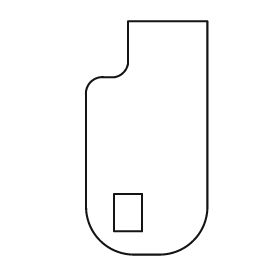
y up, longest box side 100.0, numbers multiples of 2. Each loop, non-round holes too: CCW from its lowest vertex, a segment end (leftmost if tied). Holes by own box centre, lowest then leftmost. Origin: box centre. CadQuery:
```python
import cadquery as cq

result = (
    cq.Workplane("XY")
    .moveTo(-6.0, -50.0)
    .lineTo(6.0, -50.0)
    .threePointArc((20.0, -44.0), (26.0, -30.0))
    .lineTo(26.0, 50.0)
    .lineTo(-8.0, 50.0)
    .lineTo(-8.0, 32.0)
    .threePointArc((-10.0, 28.0), (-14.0, 26.0))
    .lineTo(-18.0, 26.0)
    .threePointArc((-24.0, 24.0), (-26.0, 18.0))
    .lineTo(-26.0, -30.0)
    .threePointArc((-20.0, -44.0), (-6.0, -50.0))
    .close()
    .moveTo(-14.0, -40.0)
    .lineTo(-2.0, -40.0)
    .lineTo(-2.0, -24.0)
    .lineTo(-14.0, -24.0)
    .close()
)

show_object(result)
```